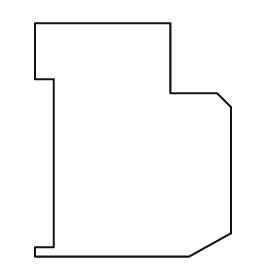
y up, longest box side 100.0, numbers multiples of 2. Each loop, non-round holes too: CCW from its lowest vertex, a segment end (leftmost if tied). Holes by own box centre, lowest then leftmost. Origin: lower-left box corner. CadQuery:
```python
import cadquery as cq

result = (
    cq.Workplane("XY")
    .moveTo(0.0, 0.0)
    .lineTo(66.0, 0.0)
    .lineTo(84.0, 10.0)
    .lineTo(84.0, 64.0)
    .lineTo(78.0, 70.0)
    .lineTo(58.0, 70.0)
    .lineTo(58.0, 100.0)
    .lineTo(0.0, 100.0)
    .lineTo(0.0, 76.0)
    .lineTo(8.0, 76.0)
    .lineTo(8.0, 4.0)
    .lineTo(0.0, 4.0)
    .close()
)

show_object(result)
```